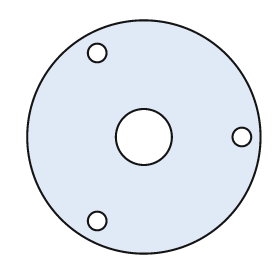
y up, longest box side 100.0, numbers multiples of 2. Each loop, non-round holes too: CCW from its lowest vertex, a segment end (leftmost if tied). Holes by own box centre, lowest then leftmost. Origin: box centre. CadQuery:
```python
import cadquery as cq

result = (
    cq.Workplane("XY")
    .moveTo(0.0, 0.0)
    .circle(50.0)
    .moveTo(-20.0, -36.0)
    .circle(4.0)
    .moveTo(0.0, 0.0)
    .circle(12.0)
    .moveTo(42.0, 0.0)
    .circle(4.0)
    .moveTo(-20.0, 36.0)
    .circle(4.0)
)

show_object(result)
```